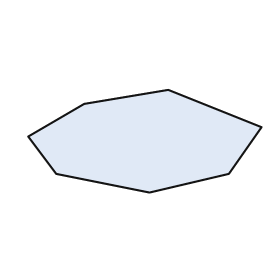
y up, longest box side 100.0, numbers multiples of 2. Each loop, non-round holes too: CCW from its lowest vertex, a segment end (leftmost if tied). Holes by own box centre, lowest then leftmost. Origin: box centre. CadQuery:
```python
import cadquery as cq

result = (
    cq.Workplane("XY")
    .moveTo(2.0, -22.0)
    .lineTo(36.0, -14.0)
    .lineTo(50.0, 6.0)
    .lineTo(10.0, 22.0)
    .lineTo(-26.0, 16.0)
    .lineTo(-50.0, 2.0)
    .lineTo(-38.0, -14.0)
    .close()
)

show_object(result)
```